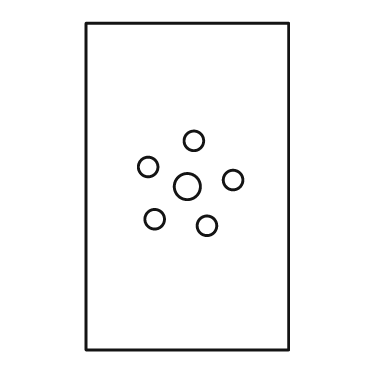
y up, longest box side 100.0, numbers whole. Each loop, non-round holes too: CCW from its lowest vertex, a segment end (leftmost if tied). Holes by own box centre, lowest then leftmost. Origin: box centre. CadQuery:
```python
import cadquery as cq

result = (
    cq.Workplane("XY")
    .moveTo(-31.0, -50.0)
    .lineTo(31.0, -50.0)
    .lineTo(31.0, 50.0)
    .lineTo(-31.0, 50.0)
    .close()
    .moveTo(6.0, -12.0)
    .circle(3.0)
    .moveTo(-10.0, -10.0)
    .circle(3.0)
    .moveTo(0.0, 0.0)
    .circle(4.0)
    .moveTo(14.0, 2.0)
    .circle(3.0)
    .moveTo(-12.0, 6.0)
    .circle(3.0)
    .moveTo(2.0, 14.0)
    .circle(3.0)
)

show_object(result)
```